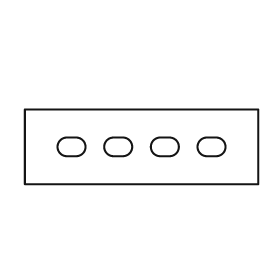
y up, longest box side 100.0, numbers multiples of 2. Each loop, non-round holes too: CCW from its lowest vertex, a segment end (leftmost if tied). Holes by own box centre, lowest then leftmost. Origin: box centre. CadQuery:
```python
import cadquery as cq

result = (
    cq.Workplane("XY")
    .moveTo(-50.0, -16.0)
    .lineTo(50.0, -16.0)
    .lineTo(50.0, 16.0)
    .lineTo(-50.0, 16.0)
    .close()
    .moveTo(-32.0, -4.0)
    .lineTo(-28.0, -4.0)
    .threePointArc((-24.0, 0.0), (-28.0, 4.0))
    .lineTo(-32.0, 4.0)
    .threePointArc((-36.0, 0.0), (-32.0, -4.0))
    .close()
    .moveTo(-12.0, -4.0)
    .lineTo(-8.0, -4.0)
    .threePointArc((-4.0, 0.0), (-8.0, 4.0))
    .lineTo(-12.0, 4.0)
    .threePointArc((-16.0, 0.0), (-12.0, -4.0))
    .close()
    .moveTo(8.0, -4.0)
    .lineTo(12.0, -4.0)
    .threePointArc((16.0, 0.0), (12.0, 4.0))
    .lineTo(8.0, 4.0)
    .threePointArc((4.0, 0.0), (8.0, -4.0))
    .close()
    .moveTo(28.0, -4.0)
    .lineTo(32.0, -4.0)
    .threePointArc((36.0, 0.0), (32.0, 4.0))
    .lineTo(28.0, 4.0)
    .threePointArc((24.0, 0.0), (28.0, -4.0))
    .close()
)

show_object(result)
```